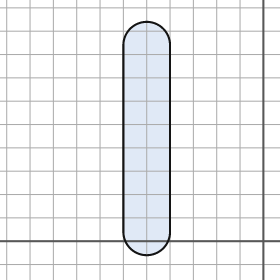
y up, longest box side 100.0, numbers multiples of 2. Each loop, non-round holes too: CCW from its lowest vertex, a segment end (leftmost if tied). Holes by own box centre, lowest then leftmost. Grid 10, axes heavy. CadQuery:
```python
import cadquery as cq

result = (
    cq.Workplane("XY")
    .moveTo(-60.0, 4.0)
    .threePointArc((-50.0, -6.0), (-40.0, 4.0))
    .lineTo(-40.0, 84.0)
    .threePointArc((-50.0, 94.0), (-60.0, 84.0))
    .close()
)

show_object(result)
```